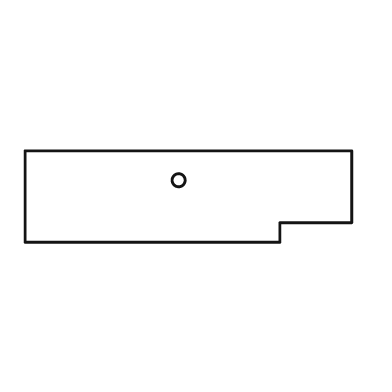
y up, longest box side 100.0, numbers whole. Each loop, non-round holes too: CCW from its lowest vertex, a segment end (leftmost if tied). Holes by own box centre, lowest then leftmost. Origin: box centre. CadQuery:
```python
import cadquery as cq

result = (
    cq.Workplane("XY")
    .moveTo(-50.0, -14.0)
    .lineTo(28.0, -14.0)
    .lineTo(28.0, -8.0)
    .lineTo(50.0, -8.0)
    .lineTo(50.0, 14.0)
    .lineTo(-50.0, 14.0)
    .close()
    .moveTo(-3.0, 5.0)
    .circle(2.0)
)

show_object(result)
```